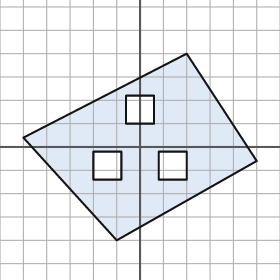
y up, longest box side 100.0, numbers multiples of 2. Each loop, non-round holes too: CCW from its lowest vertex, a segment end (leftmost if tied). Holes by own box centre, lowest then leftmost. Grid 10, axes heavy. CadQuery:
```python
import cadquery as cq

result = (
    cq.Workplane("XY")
    .moveTo(-10.0, -40.0)
    .lineTo(50.0, -6.0)
    .lineTo(20.0, 40.0)
    .lineTo(-50.0, 4.0)
    .close()
    .moveTo(-20.0, -14.0)
    .lineTo(-8.0, -14.0)
    .lineTo(-8.0, -2.0)
    .lineTo(-20.0, -2.0)
    .close()
    .moveTo(8.0, -14.0)
    .lineTo(20.0, -14.0)
    .lineTo(20.0, -2.0)
    .lineTo(8.0, -2.0)
    .close()
    .moveTo(-6.0, 10.0)
    .lineTo(6.0, 10.0)
    .lineTo(6.0, 22.0)
    .lineTo(-6.0, 22.0)
    .close()
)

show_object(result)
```